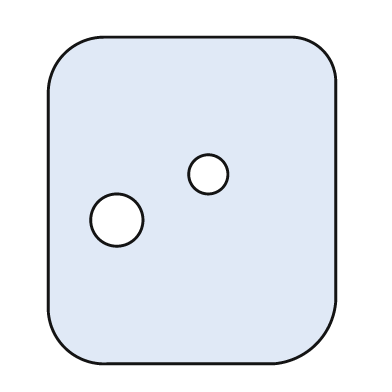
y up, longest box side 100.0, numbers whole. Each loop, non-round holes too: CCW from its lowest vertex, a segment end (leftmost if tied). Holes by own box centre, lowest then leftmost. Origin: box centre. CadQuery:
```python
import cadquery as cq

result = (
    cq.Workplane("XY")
    .moveTo(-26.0, -50.0)
    .lineTo(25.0, -50.0)
    .threePointArc((38.0, -44.0), (44.0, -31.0))
    .lineTo(44.0, 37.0)
    .threePointArc((40.0, 46.0), (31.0, 50.0))
    .lineTo(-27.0, 50.0)
    .threePointArc((-39.0, 45.0), (-44.0, 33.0))
    .lineTo(-44.0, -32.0)
    .threePointArc((-39.0, -45.0), (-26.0, -50.0))
    .close()
    .moveTo(-23.0, -6.0)
    .circle(8.0)
    .moveTo(5.0, 8.0)
    .circle(6.0)
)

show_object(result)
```